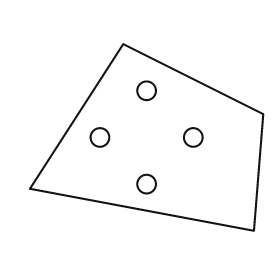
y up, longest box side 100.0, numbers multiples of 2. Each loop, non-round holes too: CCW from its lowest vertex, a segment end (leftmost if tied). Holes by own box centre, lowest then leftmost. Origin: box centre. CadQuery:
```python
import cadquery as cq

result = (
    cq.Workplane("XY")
    .moveTo(46.0, -40.0)
    .lineTo(50.0, 10.0)
    .lineTo(-10.0, 40.0)
    .lineTo(-50.0, -22.0)
    .close()
    .moveTo(0.0, -20.0)
    .circle(4.0)
    .moveTo(-20.0, 0.0)
    .circle(4.0)
    .moveTo(20.0, 0.0)
    .circle(4.0)
    .moveTo(0.0, 20.0)
    .circle(4.0)
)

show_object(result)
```